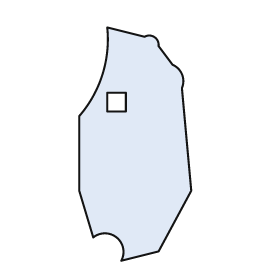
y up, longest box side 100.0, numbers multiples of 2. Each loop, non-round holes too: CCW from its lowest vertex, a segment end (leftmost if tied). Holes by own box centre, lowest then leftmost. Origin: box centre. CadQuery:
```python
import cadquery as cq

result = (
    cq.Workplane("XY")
    .moveTo(-6.0, -50.0)
    .lineTo(10.0, -46.0)
    .lineTo(24.0, -20.0)
    .lineTo(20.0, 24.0)
    .threePointArc((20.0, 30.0), (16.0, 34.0))
    .lineTo(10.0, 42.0)
    .threePointArc((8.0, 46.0), (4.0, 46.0))
    .lineTo(-12.0, 50.0)
    .threePointArc((-14.0, 30.0), (-24.0, 12.0))
    .lineTo(-24.0, -20.0)
    .lineTo(-18.0, -40.0)
    .threePointArc((-8.0, -40.0), (-6.0, -50.0))
    .close()
    .moveTo(-12.0, 14.0)
    .lineTo(-4.0, 14.0)
    .lineTo(-4.0, 22.0)
    .lineTo(-12.0, 22.0)
    .close()
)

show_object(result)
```